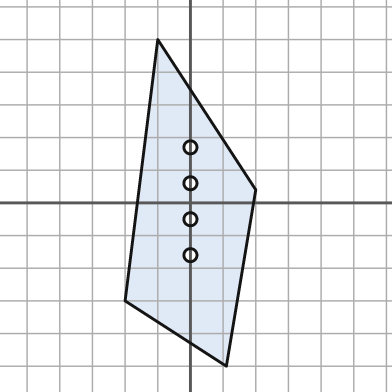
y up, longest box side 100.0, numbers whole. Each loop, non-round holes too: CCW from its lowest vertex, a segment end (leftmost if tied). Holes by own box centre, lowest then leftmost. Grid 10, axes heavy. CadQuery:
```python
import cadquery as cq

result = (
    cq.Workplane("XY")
    .moveTo(11.0, -50.0)
    .lineTo(20.0, 4.0)
    .lineTo(-10.0, 50.0)
    .lineTo(-20.0, -30.0)
    .close()
    .moveTo(0.0, -16.0)
    .circle(2.0)
    .moveTo(0.0, -5.0)
    .circle(2.0)
    .moveTo(0.0, 6.0)
    .circle(2.0)
    .moveTo(0.0, 17.0)
    .circle(2.0)
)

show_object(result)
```